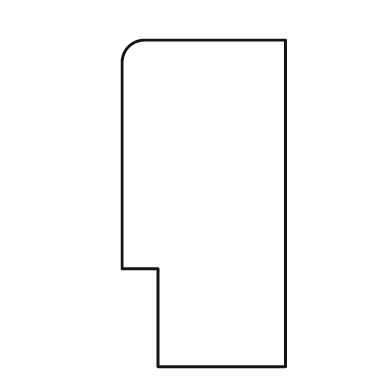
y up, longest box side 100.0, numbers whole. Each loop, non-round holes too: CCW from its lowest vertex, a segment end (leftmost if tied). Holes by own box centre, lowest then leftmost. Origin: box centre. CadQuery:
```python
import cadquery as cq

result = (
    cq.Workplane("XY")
    .moveTo(-14.0, -50.0)
    .lineTo(25.0, -50.0)
    .lineTo(25.0, 50.0)
    .lineTo(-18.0, 50.0)
    .threePointArc((-23.0, 48.0), (-25.0, 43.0))
    .lineTo(-25.0, -20.0)
    .lineTo(-14.0, -20.0)
    .close()
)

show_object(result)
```